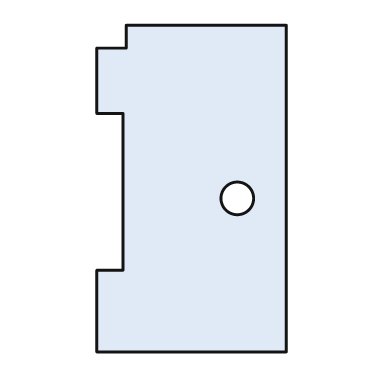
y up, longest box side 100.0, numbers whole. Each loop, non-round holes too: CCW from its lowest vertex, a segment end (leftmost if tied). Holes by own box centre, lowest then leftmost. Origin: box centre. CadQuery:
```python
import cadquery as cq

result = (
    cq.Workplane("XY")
    .moveTo(-29.0, -50.0)
    .lineTo(29.0, -50.0)
    .lineTo(29.0, 50.0)
    .lineTo(-20.0, 50.0)
    .lineTo(-20.0, 43.0)
    .lineTo(-29.0, 43.0)
    .lineTo(-29.0, 23.0)
    .lineTo(-21.0, 23.0)
    .lineTo(-21.0, -25.0)
    .lineTo(-29.0, -25.0)
    .close()
    .moveTo(14.0, -3.0)
    .circle(5.0)
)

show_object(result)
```